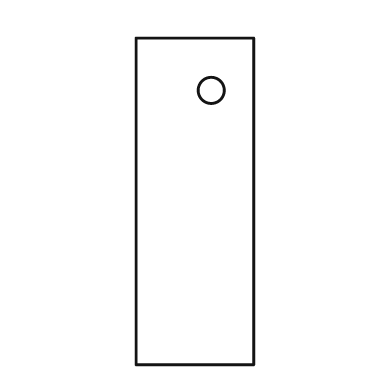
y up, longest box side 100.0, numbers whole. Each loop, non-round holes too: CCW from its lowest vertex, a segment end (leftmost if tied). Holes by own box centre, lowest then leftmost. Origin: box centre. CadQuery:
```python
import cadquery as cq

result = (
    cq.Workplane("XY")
    .moveTo(-18.0, -50.0)
    .lineTo(18.0, -50.0)
    .lineTo(18.0, 50.0)
    .lineTo(-18.0, 50.0)
    .close()
    .moveTo(5.0, 34.0)
    .circle(4.0)
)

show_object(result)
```